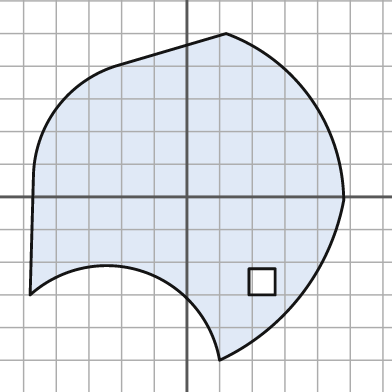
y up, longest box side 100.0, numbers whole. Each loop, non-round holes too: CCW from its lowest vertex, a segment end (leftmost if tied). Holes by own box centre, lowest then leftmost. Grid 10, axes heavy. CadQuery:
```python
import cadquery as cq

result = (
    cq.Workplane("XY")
    .moveTo(10.0, -50.0)
    .threePointArc((35.0, -30.0), (48.0, -1.0))
    .threePointArc((38.0, 30.0), (12.0, 50.0))
    .lineTo(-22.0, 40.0)
    .threePointArc((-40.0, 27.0), (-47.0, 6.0))
    .lineTo(-48.0, -30.0)
    .threePointArc((-13.0, -23.0), (10.0, -50.0))
    .close()
    .moveTo(19.0, -30.0)
    .lineTo(27.0, -30.0)
    .lineTo(27.0, -22.0)
    .lineTo(19.0, -22.0)
    .close()
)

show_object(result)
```